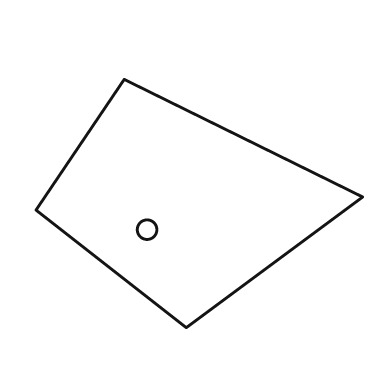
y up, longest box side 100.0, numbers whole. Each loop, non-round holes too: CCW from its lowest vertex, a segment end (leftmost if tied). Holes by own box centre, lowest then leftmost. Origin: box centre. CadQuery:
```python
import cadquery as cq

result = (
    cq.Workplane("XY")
    .moveTo(-4.0, -38.0)
    .lineTo(50.0, 2.0)
    .lineTo(-23.0, 38.0)
    .lineTo(-50.0, -2.0)
    .close()
    .moveTo(-16.0, -8.0)
    .circle(3.0)
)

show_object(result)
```